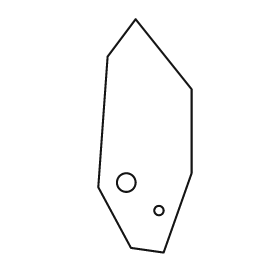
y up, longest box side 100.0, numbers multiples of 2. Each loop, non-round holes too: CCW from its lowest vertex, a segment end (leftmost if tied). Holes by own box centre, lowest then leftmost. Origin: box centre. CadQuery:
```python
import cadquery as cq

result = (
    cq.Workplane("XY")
    .moveTo(8.0, -50.0)
    .lineTo(20.0, -16.0)
    .lineTo(20.0, 20.0)
    .lineTo(-4.0, 50.0)
    .lineTo(-16.0, 34.0)
    .lineTo(-20.0, -22.0)
    .lineTo(-6.0, -48.0)
    .close()
    .moveTo(6.0, -32.0)
    .circle(2.0)
    .moveTo(-8.0, -20.0)
    .circle(4.0)
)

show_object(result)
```